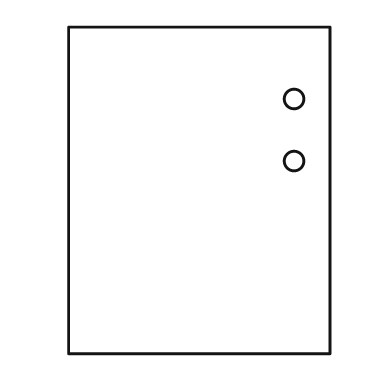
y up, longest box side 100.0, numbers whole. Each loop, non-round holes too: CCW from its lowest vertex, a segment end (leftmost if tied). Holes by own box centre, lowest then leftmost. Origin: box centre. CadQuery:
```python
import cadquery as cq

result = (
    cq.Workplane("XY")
    .moveTo(-40.0, -50.0)
    .lineTo(40.0, -50.0)
    .lineTo(40.0, 50.0)
    .lineTo(-40.0, 50.0)
    .close()
    .moveTo(29.0, 9.0)
    .circle(3.0)
    .moveTo(29.0, 28.0)
    .circle(3.0)
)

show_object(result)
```